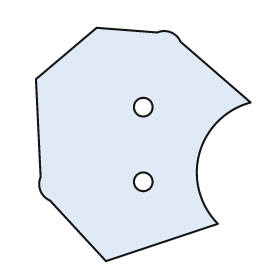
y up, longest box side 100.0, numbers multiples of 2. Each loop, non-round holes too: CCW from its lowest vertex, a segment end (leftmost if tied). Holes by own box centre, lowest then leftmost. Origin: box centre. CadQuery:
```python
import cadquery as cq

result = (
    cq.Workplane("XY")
    .moveTo(-16.0, -50.0)
    .lineTo(32.0, -34.0)
    .threePointArc((24.0, -4.0), (46.0, 18.0))
    .lineTo(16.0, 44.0)
    .threePointArc((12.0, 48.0), (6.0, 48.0))
    .lineTo(-20.0, 50.0)
    .lineTo(-46.0, 28.0)
    .lineTo(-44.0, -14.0)
    .threePointArc((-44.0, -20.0), (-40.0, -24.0))
    .close()
    .moveTo(0.0, -16.0)
    .circle(4.0)
    .moveTo(0.0, 16.0)
    .circle(4.0)
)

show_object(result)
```